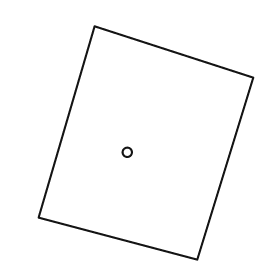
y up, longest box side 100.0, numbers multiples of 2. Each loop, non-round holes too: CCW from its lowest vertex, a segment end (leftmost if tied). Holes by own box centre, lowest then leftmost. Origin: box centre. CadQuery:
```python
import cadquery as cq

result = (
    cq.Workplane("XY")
    .moveTo(22.0, -50.0)
    .lineTo(46.0, 28.0)
    .lineTo(-22.0, 50.0)
    .lineTo(-46.0, -32.0)
    .close()
    .moveTo(-8.0, -4.0)
    .circle(2.0)
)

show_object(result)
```